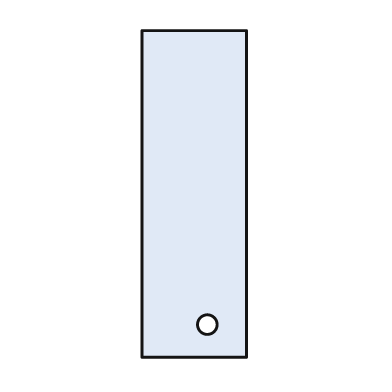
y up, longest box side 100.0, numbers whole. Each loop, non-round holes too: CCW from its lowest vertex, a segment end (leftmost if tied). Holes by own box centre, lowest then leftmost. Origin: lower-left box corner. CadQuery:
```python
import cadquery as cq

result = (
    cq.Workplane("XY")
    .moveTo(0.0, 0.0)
    .lineTo(32.0, 0.0)
    .lineTo(32.0, 100.0)
    .lineTo(0.0, 100.0)
    .close()
    .moveTo(20.0, 10.0)
    .circle(3.0)
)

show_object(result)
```